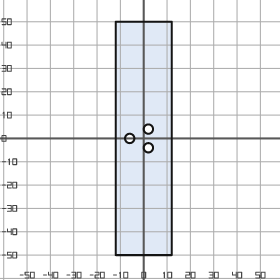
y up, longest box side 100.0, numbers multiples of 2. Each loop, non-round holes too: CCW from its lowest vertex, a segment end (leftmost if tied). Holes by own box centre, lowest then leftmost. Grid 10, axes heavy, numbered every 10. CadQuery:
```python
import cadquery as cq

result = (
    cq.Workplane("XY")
    .moveTo(-12.0, -50.0)
    .lineTo(12.0, -50.0)
    .lineTo(12.0, 50.0)
    .lineTo(-12.0, 50.0)
    .close()
    .moveTo(2.0, -4.0)
    .circle(2.0)
    .moveTo(-6.0, 0.0)
    .circle(2.0)
    .moveTo(2.0, 4.0)
    .circle(2.0)
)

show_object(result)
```